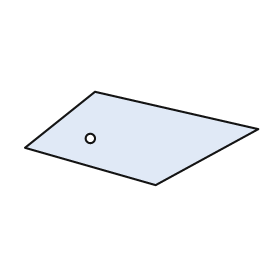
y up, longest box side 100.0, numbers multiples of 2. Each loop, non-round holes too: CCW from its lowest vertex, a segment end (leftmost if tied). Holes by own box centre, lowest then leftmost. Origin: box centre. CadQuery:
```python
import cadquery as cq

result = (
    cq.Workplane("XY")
    .moveTo(6.0, -20.0)
    .lineTo(50.0, 4.0)
    .lineTo(-20.0, 20.0)
    .lineTo(-50.0, -4.0)
    .close()
    .moveTo(-22.0, 0.0)
    .circle(2.0)
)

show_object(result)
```